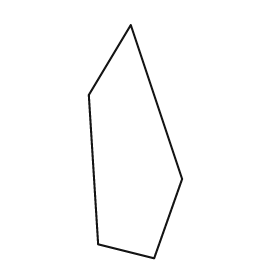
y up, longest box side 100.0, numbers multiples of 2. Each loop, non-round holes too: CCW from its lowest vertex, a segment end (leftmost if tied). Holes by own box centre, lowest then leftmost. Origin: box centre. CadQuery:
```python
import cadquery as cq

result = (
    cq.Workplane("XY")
    .moveTo(8.0, -50.0)
    .lineTo(20.0, -16.0)
    .lineTo(-2.0, 50.0)
    .lineTo(-20.0, 20.0)
    .lineTo(-16.0, -44.0)
    .close()
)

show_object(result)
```